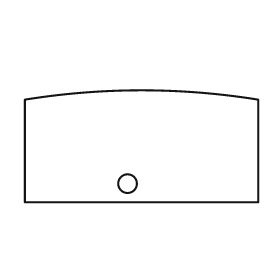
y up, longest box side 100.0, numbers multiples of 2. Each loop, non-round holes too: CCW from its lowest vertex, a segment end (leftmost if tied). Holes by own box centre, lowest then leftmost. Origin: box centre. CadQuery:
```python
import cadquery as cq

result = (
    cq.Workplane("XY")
    .moveTo(-50.0, -24.0)
    .lineTo(50.0, -24.0)
    .lineTo(50.0, 20.0)
    .threePointArc((0.0, 24.0), (-50.0, 20.0))
    .close()
    .moveTo(-6.0, -16.0)
    .circle(4.0)
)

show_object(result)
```